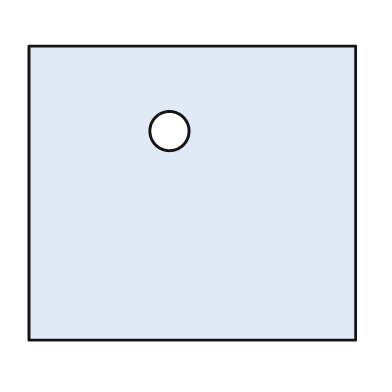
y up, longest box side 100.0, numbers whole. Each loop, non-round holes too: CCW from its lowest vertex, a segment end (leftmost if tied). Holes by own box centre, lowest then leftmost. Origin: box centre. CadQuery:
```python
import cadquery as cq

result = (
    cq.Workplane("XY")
    .moveTo(-50.0, -45.0)
    .lineTo(50.0, -45.0)
    .lineTo(50.0, 45.0)
    .lineTo(-50.0, 45.0)
    .close()
    .moveTo(-7.0, 19.0)
    .circle(6.0)
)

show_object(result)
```